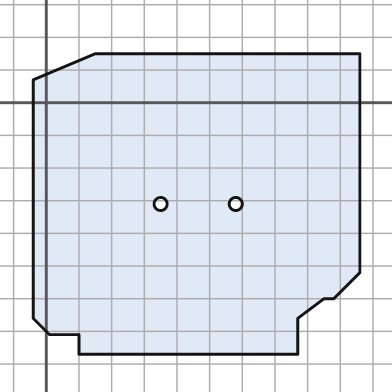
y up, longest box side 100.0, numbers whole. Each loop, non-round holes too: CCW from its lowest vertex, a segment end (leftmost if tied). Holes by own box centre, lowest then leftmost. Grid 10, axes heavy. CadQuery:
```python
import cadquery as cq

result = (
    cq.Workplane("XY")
    .moveTo(10.0, -77.0)
    .lineTo(77.0, -77.0)
    .lineTo(77.0, -66.0)
    .lineTo(85.0, -60.0)
    .lineTo(88.0, -60.0)
    .lineTo(96.0, -52.0)
    .lineTo(96.0, 15.0)
    .lineTo(15.0, 15.0)
    .lineTo(-4.0, 7.0)
    .lineTo(-4.0, -66.0)
    .lineTo(1.0, -71.0)
    .lineTo(10.0, -71.0)
    .close()
    .moveTo(35.0, -31.0)
    .circle(2.0)
    .moveTo(58.0, -31.0)
    .circle(2.0)
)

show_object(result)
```